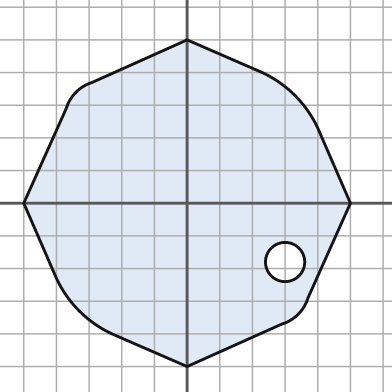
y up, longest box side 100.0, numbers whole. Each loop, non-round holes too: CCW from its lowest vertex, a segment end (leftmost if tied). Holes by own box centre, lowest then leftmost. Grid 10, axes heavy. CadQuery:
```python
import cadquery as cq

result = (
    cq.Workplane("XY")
    .moveTo(0.0, -50.0)
    .lineTo(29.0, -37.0)
    .threePointArc((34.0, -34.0), (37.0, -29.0))
    .lineTo(50.0, 0.0)
    .lineTo(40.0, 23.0)
    .threePointArc((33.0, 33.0), (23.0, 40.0))
    .lineTo(0.0, 50.0)
    .lineTo(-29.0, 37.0)
    .threePointArc((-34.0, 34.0), (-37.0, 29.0))
    .lineTo(-50.0, 0.0)
    .lineTo(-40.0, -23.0)
    .threePointArc((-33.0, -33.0), (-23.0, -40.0))
    .close()
    .moveTo(30.0, -18.0)
    .circle(6.0)
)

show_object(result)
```